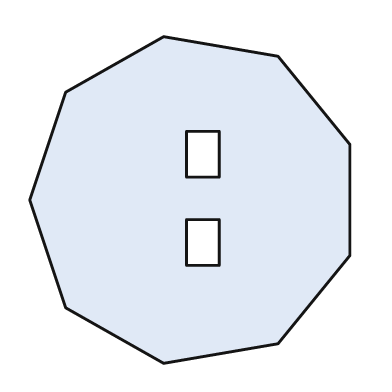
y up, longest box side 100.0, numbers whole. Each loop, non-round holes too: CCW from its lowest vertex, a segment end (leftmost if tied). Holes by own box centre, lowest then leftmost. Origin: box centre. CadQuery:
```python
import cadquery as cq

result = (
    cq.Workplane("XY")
    .moveTo(-8.0, -50.0)
    .lineTo(27.0, -44.0)
    .lineTo(49.0, -17.0)
    .lineTo(49.0, 17.0)
    .lineTo(27.0, 44.0)
    .lineTo(-8.0, 50.0)
    .lineTo(-38.0, 33.0)
    .lineTo(-49.0, 0.0)
    .lineTo(-38.0, -33.0)
    .close()
    .moveTo(-1.0, -20.0)
    .lineTo(9.0, -20.0)
    .lineTo(9.0, -6.0)
    .lineTo(-1.0, -6.0)
    .close()
    .moveTo(-1.0, 7.0)
    .lineTo(9.0, 7.0)
    .lineTo(9.0, 21.0)
    .lineTo(-1.0, 21.0)
    .close()
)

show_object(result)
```